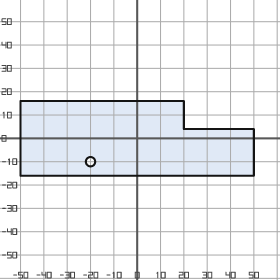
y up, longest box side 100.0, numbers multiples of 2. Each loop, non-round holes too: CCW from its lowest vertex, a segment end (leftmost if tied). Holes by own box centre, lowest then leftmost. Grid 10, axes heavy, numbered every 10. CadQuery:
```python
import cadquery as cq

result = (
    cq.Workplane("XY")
    .moveTo(-50.0, -16.0)
    .lineTo(50.0, -16.0)
    .lineTo(50.0, 4.0)
    .lineTo(20.0, 4.0)
    .lineTo(20.0, 16.0)
    .lineTo(-50.0, 16.0)
    .close()
    .moveTo(-20.0, -10.0)
    .circle(2.0)
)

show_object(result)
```